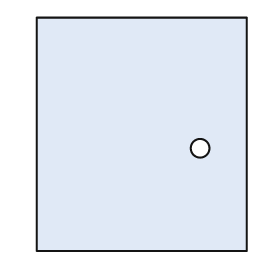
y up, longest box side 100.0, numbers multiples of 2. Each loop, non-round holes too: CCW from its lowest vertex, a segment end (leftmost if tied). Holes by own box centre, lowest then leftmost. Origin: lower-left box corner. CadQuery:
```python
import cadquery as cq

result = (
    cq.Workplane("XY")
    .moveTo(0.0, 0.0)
    .lineTo(90.0, 0.0)
    .lineTo(90.0, 100.0)
    .lineTo(0.0, 100.0)
    .close()
    .moveTo(70.0, 44.0)
    .circle(4.0)
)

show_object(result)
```